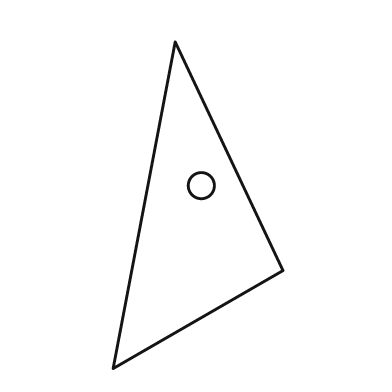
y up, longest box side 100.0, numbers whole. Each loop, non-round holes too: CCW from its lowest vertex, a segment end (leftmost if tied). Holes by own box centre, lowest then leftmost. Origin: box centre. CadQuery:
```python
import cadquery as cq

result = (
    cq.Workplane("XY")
    .moveTo(-26.0, -50.0)
    .lineTo(26.0, -20.0)
    .lineTo(-7.0, 50.0)
    .close()
    .moveTo(1.0, 6.0)
    .circle(4.0)
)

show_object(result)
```